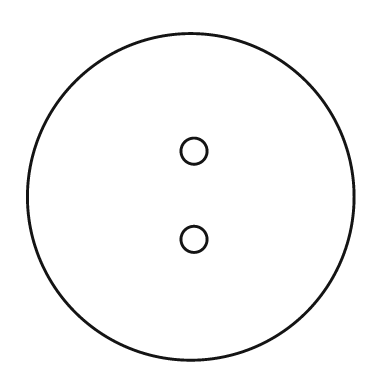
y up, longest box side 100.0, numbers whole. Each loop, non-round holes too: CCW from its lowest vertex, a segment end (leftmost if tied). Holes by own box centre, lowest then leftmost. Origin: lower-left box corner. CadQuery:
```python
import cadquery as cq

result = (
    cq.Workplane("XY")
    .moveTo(50.0, 50.0)
    .circle(50.0)
    .moveTo(51.0, 37.0)
    .circle(4.0)
    .moveTo(51.0, 64.0)
    .circle(4.0)
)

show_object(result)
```